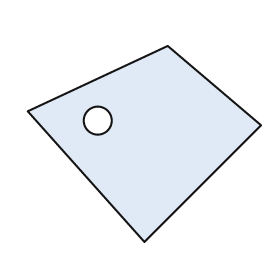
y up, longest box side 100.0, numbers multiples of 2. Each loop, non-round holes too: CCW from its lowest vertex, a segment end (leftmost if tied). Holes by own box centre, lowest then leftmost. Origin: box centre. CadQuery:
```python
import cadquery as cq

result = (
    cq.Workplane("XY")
    .moveTo(0.0, -42.0)
    .lineTo(50.0, 8.0)
    .lineTo(10.0, 42.0)
    .lineTo(-50.0, 14.0)
    .close()
    .moveTo(-20.0, 10.0)
    .circle(6.0)
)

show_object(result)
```